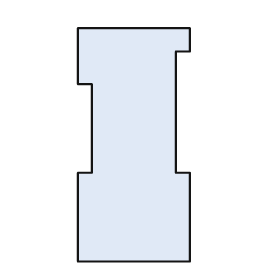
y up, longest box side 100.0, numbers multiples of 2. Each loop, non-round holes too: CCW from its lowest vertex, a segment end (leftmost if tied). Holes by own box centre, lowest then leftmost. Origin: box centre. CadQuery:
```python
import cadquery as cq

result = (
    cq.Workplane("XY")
    .moveTo(-24.0, -50.0)
    .lineTo(24.0, -50.0)
    .lineTo(24.0, -12.0)
    .lineTo(18.0, -12.0)
    .lineTo(18.0, 40.0)
    .lineTo(24.0, 40.0)
    .lineTo(24.0, 50.0)
    .lineTo(-24.0, 50.0)
    .lineTo(-24.0, 26.0)
    .lineTo(-18.0, 26.0)
    .lineTo(-18.0, -12.0)
    .lineTo(-24.0, -12.0)
    .close()
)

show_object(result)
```